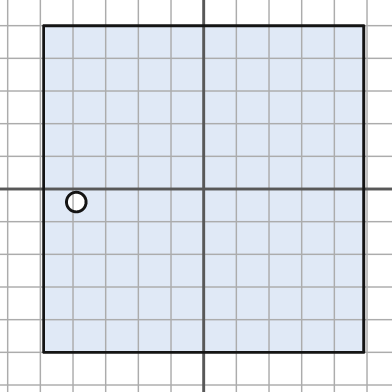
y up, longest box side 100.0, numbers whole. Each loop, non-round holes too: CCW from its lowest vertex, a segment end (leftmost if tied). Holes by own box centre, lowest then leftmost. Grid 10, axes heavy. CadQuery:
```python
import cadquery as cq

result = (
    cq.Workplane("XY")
    .moveTo(-49.0, -50.0)
    .lineTo(49.0, -50.0)
    .lineTo(49.0, 50.0)
    .lineTo(-49.0, 50.0)
    .close()
    .moveTo(-39.0, -4.0)
    .circle(3.0)
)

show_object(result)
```